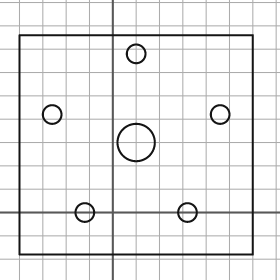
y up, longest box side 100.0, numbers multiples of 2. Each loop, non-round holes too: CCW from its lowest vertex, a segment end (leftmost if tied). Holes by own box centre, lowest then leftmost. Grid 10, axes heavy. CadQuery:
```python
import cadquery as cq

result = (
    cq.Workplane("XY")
    .moveTo(-40.0, -18.0)
    .lineTo(60.0, -18.0)
    .lineTo(60.0, 76.0)
    .lineTo(-40.0, 76.0)
    .close()
    .moveTo(-12.0, 0.0)
    .circle(4.0)
    .moveTo(32.0, 0.0)
    .circle(4.0)
    .moveTo(10.0, 30.0)
    .circle(8.0)
    .moveTo(-26.0, 42.0)
    .circle(4.0)
    .moveTo(46.0, 42.0)
    .circle(4.0)
    .moveTo(10.0, 68.0)
    .circle(4.0)
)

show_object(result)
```